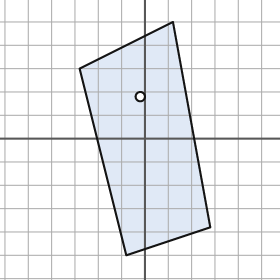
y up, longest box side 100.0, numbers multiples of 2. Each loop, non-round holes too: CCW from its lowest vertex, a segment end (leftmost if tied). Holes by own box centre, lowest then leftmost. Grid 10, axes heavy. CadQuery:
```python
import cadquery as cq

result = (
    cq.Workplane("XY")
    .moveTo(-8.0, -50.0)
    .lineTo(28.0, -38.0)
    .lineTo(12.0, 50.0)
    .lineTo(-28.0, 30.0)
    .close()
    .moveTo(-2.0, 18.0)
    .circle(2.0)
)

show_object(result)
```